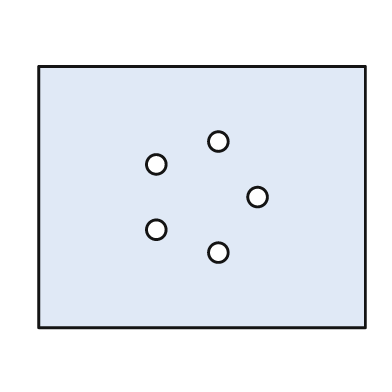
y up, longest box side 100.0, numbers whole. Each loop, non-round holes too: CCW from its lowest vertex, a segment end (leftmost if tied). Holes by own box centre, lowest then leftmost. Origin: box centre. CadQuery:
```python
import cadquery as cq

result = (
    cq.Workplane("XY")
    .moveTo(-50.0, -40.0)
    .lineTo(50.0, -40.0)
    .lineTo(50.0, 40.0)
    .lineTo(-50.0, 40.0)
    .close()
    .moveTo(5.0, -17.0)
    .circle(3.0)
    .moveTo(-14.0, -10.0)
    .circle(3.0)
    .moveTo(17.0, 0.0)
    .circle(3.0)
    .moveTo(-14.0, 10.0)
    .circle(3.0)
    .moveTo(5.0, 17.0)
    .circle(3.0)
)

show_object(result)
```